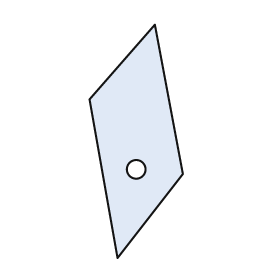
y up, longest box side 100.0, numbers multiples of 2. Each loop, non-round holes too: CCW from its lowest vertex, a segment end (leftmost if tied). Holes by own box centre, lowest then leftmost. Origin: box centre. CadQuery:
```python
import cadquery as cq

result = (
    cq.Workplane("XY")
    .moveTo(-8.0, -50.0)
    .lineTo(20.0, -14.0)
    .lineTo(8.0, 50.0)
    .lineTo(-20.0, 18.0)
    .close()
    .moveTo(0.0, -12.0)
    .circle(4.0)
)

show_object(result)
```